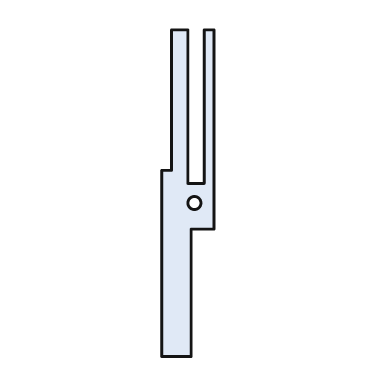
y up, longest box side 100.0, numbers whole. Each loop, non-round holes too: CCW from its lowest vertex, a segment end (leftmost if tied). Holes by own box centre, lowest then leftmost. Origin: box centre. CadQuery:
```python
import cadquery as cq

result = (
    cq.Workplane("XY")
    .moveTo(-8.0, -50.0)
    .lineTo(1.0, -50.0)
    .lineTo(1.0, -11.0)
    .lineTo(8.0, -11.0)
    .lineTo(8.0, 50.0)
    .lineTo(5.0, 50.0)
    .lineTo(5.0, 3.0)
    .lineTo(0.0, 3.0)
    .lineTo(0.0, 50.0)
    .lineTo(-5.0, 50.0)
    .lineTo(-5.0, 7.0)
    .lineTo(-8.0, 7.0)
    .close()
    .moveTo(2.0, -3.0)
    .circle(2.0)
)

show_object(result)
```